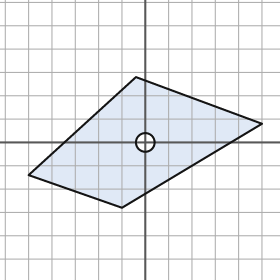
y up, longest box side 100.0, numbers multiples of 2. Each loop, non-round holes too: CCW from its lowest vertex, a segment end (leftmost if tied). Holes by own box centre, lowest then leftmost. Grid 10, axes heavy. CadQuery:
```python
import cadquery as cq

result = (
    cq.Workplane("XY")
    .moveTo(-10.0, -28.0)
    .lineTo(50.0, 8.0)
    .lineTo(-4.0, 28.0)
    .lineTo(-50.0, -14.0)
    .close()
    .moveTo(0.0, 0.0)
    .circle(4.0)
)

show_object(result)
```